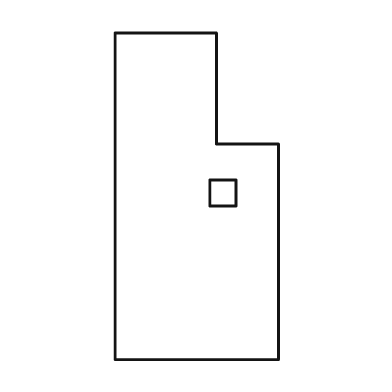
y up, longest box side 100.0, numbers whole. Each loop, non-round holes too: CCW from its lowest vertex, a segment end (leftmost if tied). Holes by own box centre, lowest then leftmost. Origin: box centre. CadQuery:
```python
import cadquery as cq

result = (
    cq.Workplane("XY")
    .moveTo(-25.0, -50.0)
    .lineTo(25.0, -50.0)
    .lineTo(25.0, 16.0)
    .lineTo(6.0, 16.0)
    .lineTo(6.0, 50.0)
    .lineTo(-25.0, 50.0)
    .close()
    .moveTo(4.0, -3.0)
    .lineTo(12.0, -3.0)
    .lineTo(12.0, 5.0)
    .lineTo(4.0, 5.0)
    .close()
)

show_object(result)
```